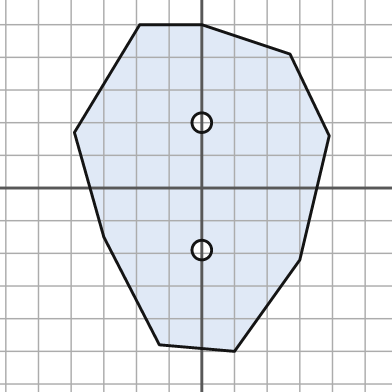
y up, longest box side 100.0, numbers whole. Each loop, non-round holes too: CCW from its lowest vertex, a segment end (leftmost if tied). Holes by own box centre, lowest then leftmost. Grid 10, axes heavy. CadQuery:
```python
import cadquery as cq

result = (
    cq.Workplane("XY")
    .moveTo(10.0, -50.0)
    .lineTo(30.0, -22.0)
    .lineTo(39.0, 16.0)
    .lineTo(27.0, 41.0)
    .lineTo(0.0, 50.0)
    .lineTo(-19.0, 50.0)
    .lineTo(-39.0, 17.0)
    .lineTo(-30.0, -15.0)
    .lineTo(-13.0, -48.0)
    .close()
    .moveTo(0.0, -19.0)
    .circle(3.0)
    .moveTo(0.0, 20.0)
    .circle(3.0)
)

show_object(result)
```